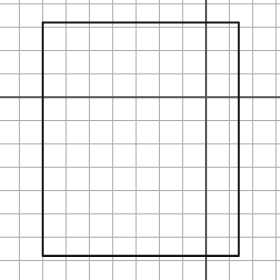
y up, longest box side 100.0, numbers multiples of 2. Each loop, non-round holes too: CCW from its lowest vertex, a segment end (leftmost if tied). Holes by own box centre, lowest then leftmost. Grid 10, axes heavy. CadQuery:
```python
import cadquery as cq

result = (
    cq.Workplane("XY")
    .moveTo(-70.0, -68.0)
    .lineTo(14.0, -68.0)
    .lineTo(14.0, 32.0)
    .lineTo(-70.0, 32.0)
    .close()
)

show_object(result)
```